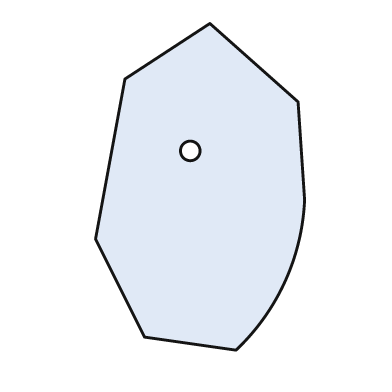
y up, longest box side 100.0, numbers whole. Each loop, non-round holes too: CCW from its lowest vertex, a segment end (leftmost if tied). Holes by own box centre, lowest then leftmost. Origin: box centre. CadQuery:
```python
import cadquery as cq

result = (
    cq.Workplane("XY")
    .moveTo(11.0, -50.0)
    .threePointArc((26.0, -29.0), (32.0, -4.0))
    .lineTo(30.0, 26.0)
    .lineTo(3.0, 50.0)
    .lineTo(-23.0, 33.0)
    .lineTo(-32.0, -16.0)
    .lineTo(-17.0, -46.0)
    .close()
    .moveTo(-3.0, 11.0)
    .circle(3.0)
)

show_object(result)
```